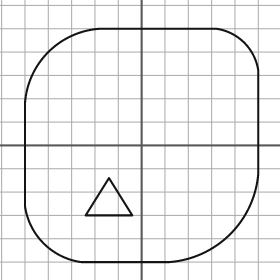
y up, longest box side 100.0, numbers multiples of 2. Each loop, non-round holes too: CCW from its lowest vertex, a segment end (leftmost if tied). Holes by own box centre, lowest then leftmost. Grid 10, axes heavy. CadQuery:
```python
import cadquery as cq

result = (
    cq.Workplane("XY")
    .moveTo(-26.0, -50.0)
    .lineTo(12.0, -50.0)
    .threePointArc((38.0, -38.0), (50.0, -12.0))
    .lineTo(50.0, 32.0)
    .threePointArc((44.0, 44.0), (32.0, 50.0))
    .lineTo(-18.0, 50.0)
    .threePointArc((-40.0, 40.0), (-50.0, 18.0))
    .lineTo(-50.0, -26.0)
    .threePointArc((-42.0, -42.0), (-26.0, -50.0))
    .close()
    .moveTo(-24.0, -30.0)
    .lineTo(-4.0, -30.0)
    .lineTo(-14.0, -14.0)
    .close()
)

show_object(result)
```